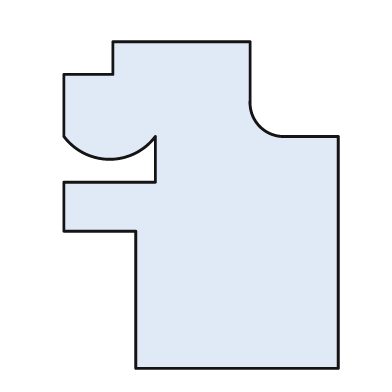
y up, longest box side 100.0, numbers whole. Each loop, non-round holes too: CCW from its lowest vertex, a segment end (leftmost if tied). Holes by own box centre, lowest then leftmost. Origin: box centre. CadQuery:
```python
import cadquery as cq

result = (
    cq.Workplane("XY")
    .moveTo(-20.0, -50.0)
    .lineTo(42.0, -50.0)
    .lineTo(42.0, 21.0)
    .lineTo(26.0, 21.0)
    .threePointArc((18.0, 24.0), (15.0, 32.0))
    .lineTo(15.0, 50.0)
    .lineTo(-27.0, 50.0)
    .lineTo(-27.0, 40.0)
    .lineTo(-42.0, 40.0)
    .lineTo(-42.0, 21.0)
    .threePointArc((-28.0, 14.0), (-14.0, 21.0))
    .lineTo(-14.0, 7.0)
    .lineTo(-42.0, 7.0)
    .lineTo(-42.0, -8.0)
    .lineTo(-20.0, -8.0)
    .close()
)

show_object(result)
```